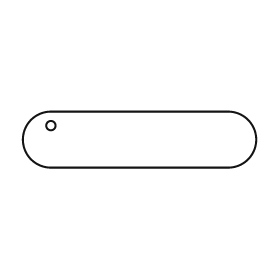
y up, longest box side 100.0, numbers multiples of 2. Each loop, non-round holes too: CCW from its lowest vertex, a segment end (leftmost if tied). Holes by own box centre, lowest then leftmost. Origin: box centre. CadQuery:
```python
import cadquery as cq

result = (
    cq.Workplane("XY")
    .moveTo(-38.0, -12.0)
    .lineTo(38.0, -12.0)
    .threePointArc((50.0, 0.0), (38.0, 12.0))
    .lineTo(-38.0, 12.0)
    .threePointArc((-50.0, 0.0), (-38.0, -12.0))
    .close()
    .moveTo(-38.0, 6.0)
    .circle(2.0)
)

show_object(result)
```